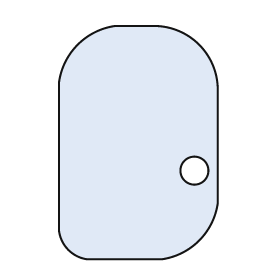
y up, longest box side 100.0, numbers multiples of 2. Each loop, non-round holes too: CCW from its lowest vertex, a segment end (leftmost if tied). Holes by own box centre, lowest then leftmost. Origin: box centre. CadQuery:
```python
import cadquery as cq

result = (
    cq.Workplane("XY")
    .moveTo(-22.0, -50.0)
    .lineTo(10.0, -50.0)
    .threePointArc((26.0, -42.0), (34.0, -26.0))
    .lineTo(34.0, 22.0)
    .threePointArc((26.0, 42.0), (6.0, 50.0))
    .lineTo(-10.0, 50.0)
    .threePointArc((-26.0, 42.0), (-34.0, 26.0))
    .lineTo(-34.0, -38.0)
    .threePointArc((-30.0, -46.0), (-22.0, -50.0))
    .close()
    .moveTo(24.0, -12.0)
    .circle(6.0)
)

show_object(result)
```